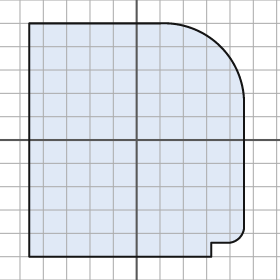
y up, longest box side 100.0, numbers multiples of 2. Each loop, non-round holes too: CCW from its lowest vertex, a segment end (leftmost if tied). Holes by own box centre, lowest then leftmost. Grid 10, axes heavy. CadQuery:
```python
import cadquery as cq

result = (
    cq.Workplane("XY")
    .moveTo(-46.0, -50.0)
    .lineTo(32.0, -50.0)
    .lineTo(32.0, -44.0)
    .lineTo(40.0, -44.0)
    .threePointArc((44.0, -42.0), (46.0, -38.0))
    .lineTo(46.0, 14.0)
    .threePointArc((36.0, 40.0), (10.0, 50.0))
    .lineTo(-46.0, 50.0)
    .close()
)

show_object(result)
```